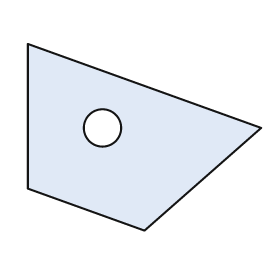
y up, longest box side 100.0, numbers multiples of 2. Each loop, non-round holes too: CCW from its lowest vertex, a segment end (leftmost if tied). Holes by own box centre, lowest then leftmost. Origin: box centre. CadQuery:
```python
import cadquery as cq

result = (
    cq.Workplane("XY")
    .moveTo(0.0, -40.0)
    .lineTo(50.0, 4.0)
    .lineTo(-50.0, 40.0)
    .lineTo(-50.0, -22.0)
    .close()
    .moveTo(-18.0, 4.0)
    .circle(8.0)
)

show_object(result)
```